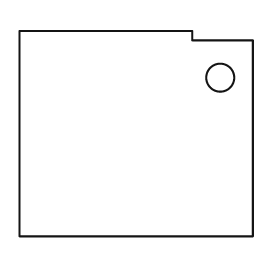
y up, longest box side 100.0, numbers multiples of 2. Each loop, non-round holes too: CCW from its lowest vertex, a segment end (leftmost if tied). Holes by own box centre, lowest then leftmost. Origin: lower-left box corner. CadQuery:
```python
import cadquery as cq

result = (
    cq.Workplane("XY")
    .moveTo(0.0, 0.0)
    .lineTo(100.0, 0.0)
    .lineTo(100.0, 84.0)
    .lineTo(74.0, 84.0)
    .lineTo(74.0, 88.0)
    .lineTo(0.0, 88.0)
    .close()
    .moveTo(86.0, 68.0)
    .circle(6.0)
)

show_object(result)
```